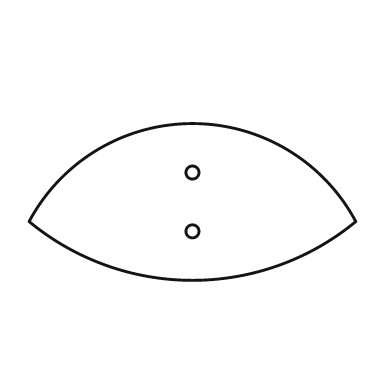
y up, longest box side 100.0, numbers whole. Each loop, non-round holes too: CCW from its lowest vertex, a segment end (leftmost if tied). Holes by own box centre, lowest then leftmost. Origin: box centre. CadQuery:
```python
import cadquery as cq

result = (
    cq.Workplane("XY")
    .moveTo(-50.0, -6.0)
    .threePointArc((0.0, -24.0), (50.0, -6.0))
    .threePointArc((0.0, 24.0), (-50.0, -6.0))
    .close()
    .moveTo(0.0, -9.0)
    .circle(2.0)
    .moveTo(0.0, 9.0)
    .circle(2.0)
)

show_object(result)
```